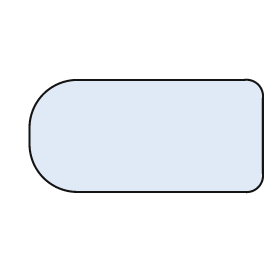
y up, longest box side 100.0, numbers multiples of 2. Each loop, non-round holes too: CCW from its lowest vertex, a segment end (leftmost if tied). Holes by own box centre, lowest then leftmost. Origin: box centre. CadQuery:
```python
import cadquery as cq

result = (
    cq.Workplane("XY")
    .moveTo(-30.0, -24.0)
    .lineTo(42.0, -24.0)
    .threePointArc((48.0, -22.0), (50.0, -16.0))
    .lineTo(50.0, 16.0)
    .threePointArc((48.0, 22.0), (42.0, 24.0))
    .lineTo(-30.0, 24.0)
    .threePointArc((-44.0, 18.0), (-50.0, 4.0))
    .lineTo(-50.0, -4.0)
    .threePointArc((-44.0, -18.0), (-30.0, -24.0))
    .close()
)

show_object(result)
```